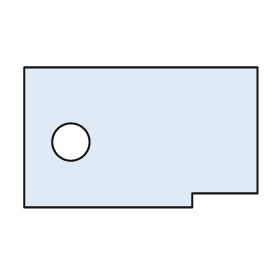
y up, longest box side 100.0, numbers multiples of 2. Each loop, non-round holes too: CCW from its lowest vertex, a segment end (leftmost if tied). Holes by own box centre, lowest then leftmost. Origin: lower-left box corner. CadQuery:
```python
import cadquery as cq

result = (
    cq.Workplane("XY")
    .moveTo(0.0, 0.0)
    .lineTo(72.0, 0.0)
    .lineTo(72.0, 6.0)
    .lineTo(100.0, 6.0)
    .lineTo(100.0, 60.0)
    .lineTo(0.0, 60.0)
    .close()
    .moveTo(20.0, 28.0)
    .circle(8.0)
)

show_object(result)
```